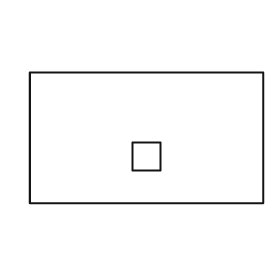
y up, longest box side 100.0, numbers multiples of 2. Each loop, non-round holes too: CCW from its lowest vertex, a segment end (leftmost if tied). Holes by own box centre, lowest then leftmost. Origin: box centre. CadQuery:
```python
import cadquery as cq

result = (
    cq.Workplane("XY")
    .moveTo(-50.0, -28.0)
    .lineTo(50.0, -28.0)
    .lineTo(50.0, 28.0)
    .lineTo(-50.0, 28.0)
    .close()
    .moveTo(-6.0, -14.0)
    .lineTo(6.0, -14.0)
    .lineTo(6.0, -2.0)
    .lineTo(-6.0, -2.0)
    .close()
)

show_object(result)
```